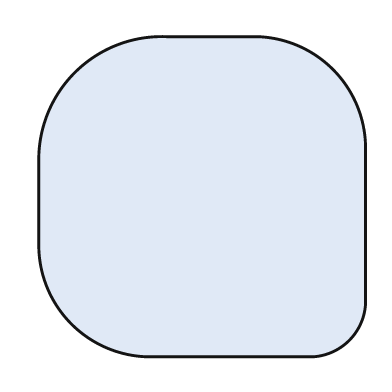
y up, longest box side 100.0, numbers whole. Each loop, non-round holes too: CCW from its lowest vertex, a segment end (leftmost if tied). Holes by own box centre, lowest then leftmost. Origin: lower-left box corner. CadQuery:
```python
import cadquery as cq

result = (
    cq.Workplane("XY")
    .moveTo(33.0, 0.0)
    .lineTo(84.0, 0.0)
    .threePointArc((95.0, 5.0), (100.0, 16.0))
    .lineTo(100.0, 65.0)
    .threePointArc((90.0, 88.0), (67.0, 98.0))
    .lineTo(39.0, 98.0)
    .threePointArc((11.0, 87.0), (0.0, 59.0))
    .lineTo(0.0, 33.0)
    .threePointArc((10.0, 10.0), (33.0, 0.0))
    .close()
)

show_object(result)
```